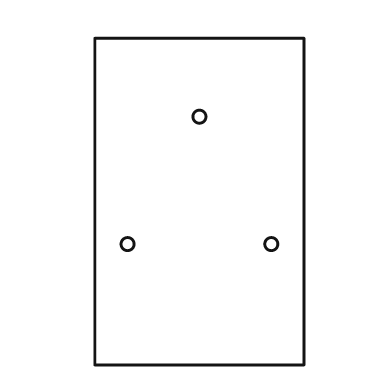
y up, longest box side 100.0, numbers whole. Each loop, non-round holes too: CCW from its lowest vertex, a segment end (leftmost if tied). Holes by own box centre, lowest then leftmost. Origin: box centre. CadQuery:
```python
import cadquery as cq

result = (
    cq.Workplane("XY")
    .moveTo(-32.0, -50.0)
    .lineTo(32.0, -50.0)
    .lineTo(32.0, 50.0)
    .lineTo(-32.0, 50.0)
    .close()
    .moveTo(-22.0, -13.0)
    .circle(2.0)
    .moveTo(22.0, -13.0)
    .circle(2.0)
    .moveTo(0.0, 26.0)
    .circle(2.0)
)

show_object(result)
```